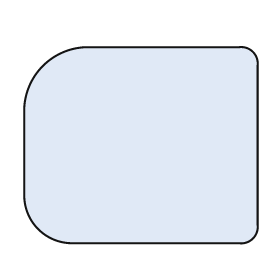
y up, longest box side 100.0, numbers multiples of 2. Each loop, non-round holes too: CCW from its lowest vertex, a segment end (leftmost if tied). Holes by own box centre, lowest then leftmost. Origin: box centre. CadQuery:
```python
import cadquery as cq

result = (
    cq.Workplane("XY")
    .moveTo(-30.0, -42.0)
    .lineTo(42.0, -42.0)
    .threePointArc((48.0, -40.0), (50.0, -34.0))
    .lineTo(50.0, 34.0)
    .threePointArc((48.0, 40.0), (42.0, 42.0))
    .lineTo(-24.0, 42.0)
    .threePointArc((-42.0, 34.0), (-50.0, 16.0))
    .lineTo(-50.0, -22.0)
    .threePointArc((-44.0, -36.0), (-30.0, -42.0))
    .close()
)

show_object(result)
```